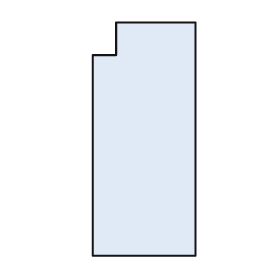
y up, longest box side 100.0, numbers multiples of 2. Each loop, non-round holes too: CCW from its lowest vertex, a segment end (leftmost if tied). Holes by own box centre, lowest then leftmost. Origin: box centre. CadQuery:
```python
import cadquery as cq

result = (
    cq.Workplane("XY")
    .moveTo(-22.0, -50.0)
    .lineTo(22.0, -50.0)
    .lineTo(22.0, 50.0)
    .lineTo(-12.0, 50.0)
    .lineTo(-12.0, 36.0)
    .lineTo(-22.0, 36.0)
    .close()
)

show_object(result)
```